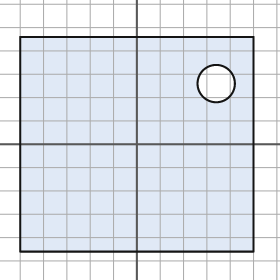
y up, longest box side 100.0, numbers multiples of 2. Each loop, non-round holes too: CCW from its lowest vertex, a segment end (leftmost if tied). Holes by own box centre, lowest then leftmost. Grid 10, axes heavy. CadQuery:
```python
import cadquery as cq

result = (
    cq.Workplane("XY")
    .moveTo(-50.0, -46.0)
    .lineTo(50.0, -46.0)
    .lineTo(50.0, 46.0)
    .lineTo(-50.0, 46.0)
    .close()
    .moveTo(34.0, 26.0)
    .circle(8.0)
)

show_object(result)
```